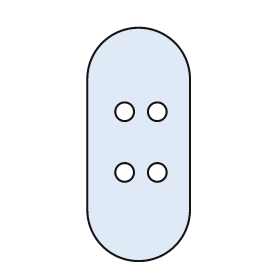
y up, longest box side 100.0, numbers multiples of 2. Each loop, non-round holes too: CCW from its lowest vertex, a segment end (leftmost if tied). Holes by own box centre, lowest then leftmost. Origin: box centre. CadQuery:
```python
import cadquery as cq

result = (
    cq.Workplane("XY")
    .moveTo(-22.0, -28.0)
    .threePointArc((0.0, -50.0), (22.0, -28.0))
    .lineTo(22.0, 28.0)
    .threePointArc((0.0, 50.0), (-22.0, 28.0))
    .close()
    .moveTo(-6.0, -12.0)
    .circle(4.0)
    .moveTo(8.0, -12.0)
    .circle(4.0)
    .moveTo(-6.0, 14.0)
    .circle(4.0)
    .moveTo(8.0, 14.0)
    .circle(4.0)
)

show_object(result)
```